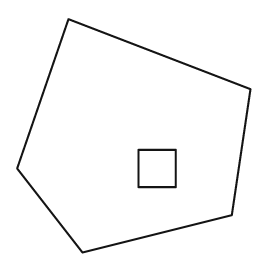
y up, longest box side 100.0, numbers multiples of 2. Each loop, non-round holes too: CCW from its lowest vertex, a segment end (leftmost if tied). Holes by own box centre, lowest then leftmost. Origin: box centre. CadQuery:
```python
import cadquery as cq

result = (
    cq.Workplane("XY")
    .moveTo(-22.0, -50.0)
    .lineTo(42.0, -34.0)
    .lineTo(50.0, 20.0)
    .lineTo(-28.0, 50.0)
    .lineTo(-50.0, -14.0)
    .close()
    .moveTo(2.0, -22.0)
    .lineTo(18.0, -22.0)
    .lineTo(18.0, -6.0)
    .lineTo(2.0, -6.0)
    .close()
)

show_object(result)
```